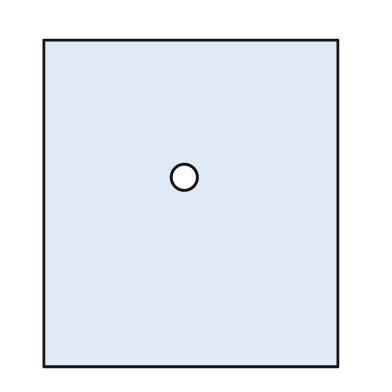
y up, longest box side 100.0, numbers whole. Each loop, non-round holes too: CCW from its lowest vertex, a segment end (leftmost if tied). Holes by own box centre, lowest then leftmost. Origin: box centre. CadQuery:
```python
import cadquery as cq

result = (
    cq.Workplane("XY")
    .moveTo(-45.0, -50.0)
    .lineTo(45.0, -50.0)
    .lineTo(45.0, 50.0)
    .lineTo(-45.0, 50.0)
    .close()
    .moveTo(-2.0, 8.0)
    .circle(4.0)
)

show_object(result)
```